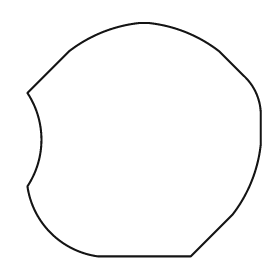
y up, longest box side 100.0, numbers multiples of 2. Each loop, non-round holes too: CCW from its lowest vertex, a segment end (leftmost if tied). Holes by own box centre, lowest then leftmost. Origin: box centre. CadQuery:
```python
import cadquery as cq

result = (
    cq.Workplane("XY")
    .moveTo(-20.0, -50.0)
    .lineTo(20.0, -50.0)
    .lineTo(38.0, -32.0)
    .threePointArc((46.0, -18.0), (50.0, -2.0))
    .lineTo(50.0, 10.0)
    .threePointArc((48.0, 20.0), (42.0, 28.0))
    .lineTo(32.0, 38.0)
    .threePointArc((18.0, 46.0), (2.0, 50.0))
    .lineTo(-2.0, 50.0)
    .threePointArc((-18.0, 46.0), (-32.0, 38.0))
    .lineTo(-50.0, 20.0)
    .threePointArc((-44.0, 0.0), (-50.0, -20.0))
    .threePointArc((-40.0, -40.0), (-20.0, -50.0))
    .close()
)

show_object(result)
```